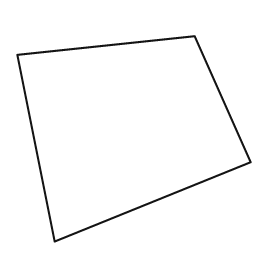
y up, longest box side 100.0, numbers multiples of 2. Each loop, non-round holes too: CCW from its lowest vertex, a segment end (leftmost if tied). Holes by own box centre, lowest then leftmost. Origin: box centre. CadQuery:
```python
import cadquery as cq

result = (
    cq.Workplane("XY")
    .moveTo(-34.0, -44.0)
    .lineTo(50.0, -10.0)
    .lineTo(26.0, 44.0)
    .lineTo(-50.0, 36.0)
    .close()
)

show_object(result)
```